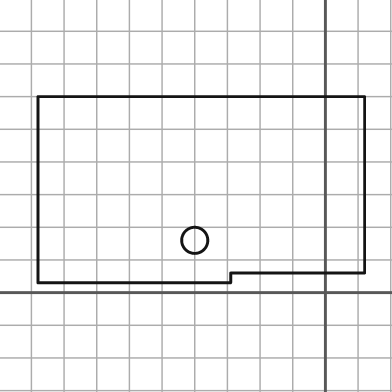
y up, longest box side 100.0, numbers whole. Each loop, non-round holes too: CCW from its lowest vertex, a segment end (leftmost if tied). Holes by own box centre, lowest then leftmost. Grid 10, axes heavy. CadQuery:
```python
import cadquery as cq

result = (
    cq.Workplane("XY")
    .moveTo(-88.0, 3.0)
    .lineTo(-29.0, 3.0)
    .lineTo(-29.0, 6.0)
    .lineTo(12.0, 6.0)
    .lineTo(12.0, 60.0)
    .lineTo(-88.0, 60.0)
    .close()
    .moveTo(-40.0, 16.0)
    .circle(4.0)
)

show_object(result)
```